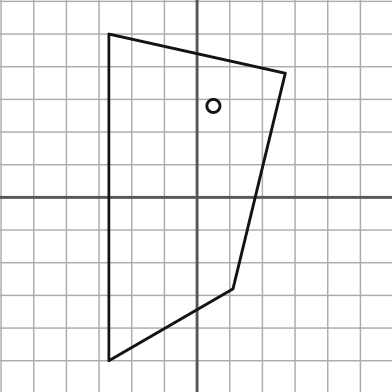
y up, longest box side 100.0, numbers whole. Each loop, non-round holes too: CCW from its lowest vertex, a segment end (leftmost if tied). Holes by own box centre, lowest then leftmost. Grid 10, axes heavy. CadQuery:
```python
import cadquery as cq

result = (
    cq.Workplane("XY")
    .moveTo(-27.0, -50.0)
    .lineTo(11.0, -28.0)
    .lineTo(27.0, 38.0)
    .lineTo(-27.0, 50.0)
    .close()
    .moveTo(5.0, 28.0)
    .circle(2.0)
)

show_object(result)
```